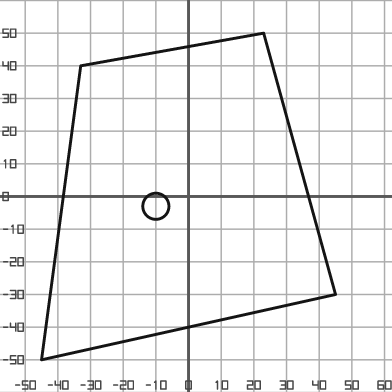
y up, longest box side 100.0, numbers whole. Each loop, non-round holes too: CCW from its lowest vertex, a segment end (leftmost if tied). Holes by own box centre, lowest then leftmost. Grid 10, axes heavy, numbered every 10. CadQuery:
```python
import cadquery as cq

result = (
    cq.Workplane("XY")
    .moveTo(-45.0, -50.0)
    .lineTo(45.0, -30.0)
    .lineTo(23.0, 50.0)
    .lineTo(-33.0, 40.0)
    .close()
    .moveTo(-10.0, -3.0)
    .circle(4.0)
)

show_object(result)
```